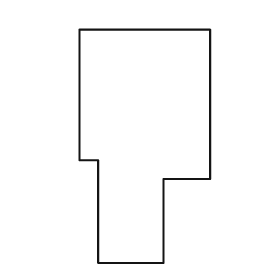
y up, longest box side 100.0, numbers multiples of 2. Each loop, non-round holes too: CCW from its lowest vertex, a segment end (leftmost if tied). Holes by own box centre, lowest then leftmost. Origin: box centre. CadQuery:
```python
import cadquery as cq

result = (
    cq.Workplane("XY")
    .moveTo(-20.0, -50.0)
    .lineTo(8.0, -50.0)
    .lineTo(8.0, -14.0)
    .lineTo(28.0, -14.0)
    .lineTo(28.0, 50.0)
    .lineTo(-28.0, 50.0)
    .lineTo(-28.0, -6.0)
    .lineTo(-20.0, -6.0)
    .close()
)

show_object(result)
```